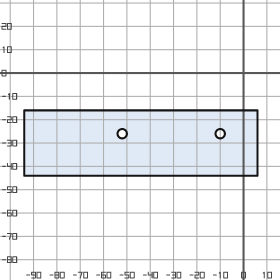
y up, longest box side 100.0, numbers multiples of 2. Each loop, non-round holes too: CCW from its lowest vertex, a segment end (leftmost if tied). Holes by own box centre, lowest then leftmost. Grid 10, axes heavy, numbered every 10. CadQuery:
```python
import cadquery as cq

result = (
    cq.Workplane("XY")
    .moveTo(-94.0, -44.0)
    .lineTo(6.0, -44.0)
    .lineTo(6.0, -16.0)
    .lineTo(-94.0, -16.0)
    .close()
    .moveTo(-52.0, -26.0)
    .circle(2.0)
    .moveTo(-10.0, -26.0)
    .circle(2.0)
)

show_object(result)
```